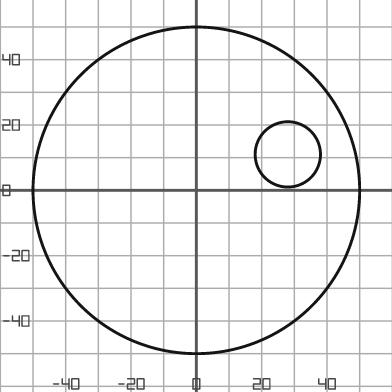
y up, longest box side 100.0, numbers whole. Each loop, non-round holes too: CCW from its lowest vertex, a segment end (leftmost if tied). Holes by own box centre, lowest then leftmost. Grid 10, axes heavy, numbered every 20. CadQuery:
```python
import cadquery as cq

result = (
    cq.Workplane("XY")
    .moveTo(0.0, 0.0)
    .circle(50.0)
    .moveTo(28.0, 11.0)
    .circle(10.0)
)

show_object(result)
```